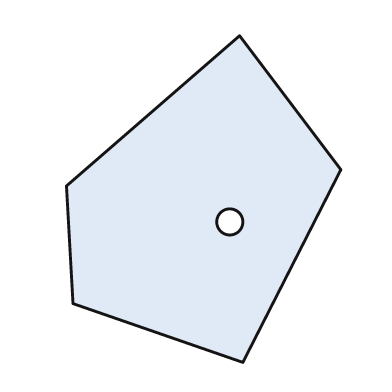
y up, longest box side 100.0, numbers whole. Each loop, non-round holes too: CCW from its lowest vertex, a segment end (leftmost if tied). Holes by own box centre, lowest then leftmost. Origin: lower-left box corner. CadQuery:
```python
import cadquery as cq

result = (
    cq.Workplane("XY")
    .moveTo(54.0, 0.0)
    .lineTo(84.0, 59.0)
    .lineTo(53.0, 100.0)
    .lineTo(0.0, 54.0)
    .lineTo(2.0, 18.0)
    .close()
    .moveTo(50.0, 43.0)
    .circle(4.0)
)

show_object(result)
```